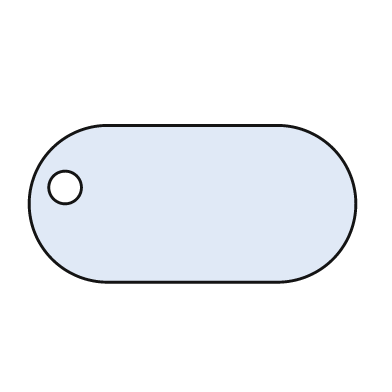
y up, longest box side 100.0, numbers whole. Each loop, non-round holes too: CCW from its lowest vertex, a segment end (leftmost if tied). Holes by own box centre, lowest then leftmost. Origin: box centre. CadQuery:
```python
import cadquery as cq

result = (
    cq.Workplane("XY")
    .moveTo(-26.0, -24.0)
    .lineTo(26.0, -24.0)
    .threePointArc((50.0, 0.0), (26.0, 24.0))
    .lineTo(-26.0, 24.0)
    .threePointArc((-50.0, 0.0), (-26.0, -24.0))
    .close()
    .moveTo(-39.0, 5.0)
    .circle(5.0)
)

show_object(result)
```